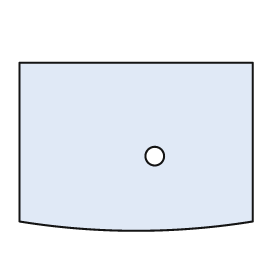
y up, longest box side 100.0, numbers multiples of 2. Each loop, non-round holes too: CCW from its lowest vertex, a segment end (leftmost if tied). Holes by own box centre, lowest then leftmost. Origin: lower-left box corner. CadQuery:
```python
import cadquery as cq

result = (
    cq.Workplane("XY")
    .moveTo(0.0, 4.0)
    .threePointArc((50.0, 0.0), (100.0, 4.0))
    .lineTo(100.0, 72.0)
    .lineTo(0.0, 72.0)
    .close()
    .moveTo(58.0, 32.0)
    .circle(4.0)
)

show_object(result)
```